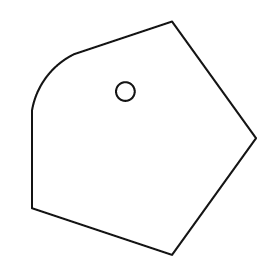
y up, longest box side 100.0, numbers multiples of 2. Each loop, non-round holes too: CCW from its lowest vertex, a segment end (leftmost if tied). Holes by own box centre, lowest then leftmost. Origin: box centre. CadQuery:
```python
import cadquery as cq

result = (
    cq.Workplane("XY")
    .moveTo(12.0, -50.0)
    .lineTo(48.0, 0.0)
    .lineTo(12.0, 50.0)
    .lineTo(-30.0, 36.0)
    .threePointArc((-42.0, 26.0), (-48.0, 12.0))
    .lineTo(-48.0, -30.0)
    .close()
    .moveTo(-8.0, 20.0)
    .circle(4.0)
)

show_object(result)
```